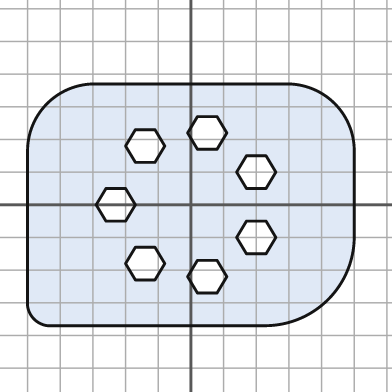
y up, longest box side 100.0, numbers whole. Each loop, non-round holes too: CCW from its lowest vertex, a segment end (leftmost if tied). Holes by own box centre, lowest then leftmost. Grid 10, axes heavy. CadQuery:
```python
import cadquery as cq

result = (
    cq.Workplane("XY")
    .moveTo(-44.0, -37.0)
    .lineTo(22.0, -37.0)
    .threePointArc((42.0, -29.0), (50.0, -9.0))
    .lineTo(50.0, 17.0)
    .threePointArc((44.0, 31.0), (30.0, 37.0))
    .lineTo(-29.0, 37.0)
    .threePointArc((-44.0, 31.0), (-50.0, 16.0))
    .lineTo(-50.0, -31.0)
    .threePointArc((-48.0, -35.0), (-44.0, -37.0))
    .close()
    .moveTo(2.0, -27.0)
    .lineTo(8.0, -27.0)
    .lineTo(11.0, -22.0)
    .lineTo(8.0, -17.0)
    .lineTo(2.0, -17.0)
    .lineTo(-1.0, -22.0)
    .close()
    .moveTo(-17.0, -23.0)
    .lineTo(-11.0, -23.0)
    .lineTo(-8.0, -18.0)
    .lineTo(-11.0, -13.0)
    .lineTo(-17.0, -13.0)
    .lineTo(-20.0, -18.0)
    .close()
    .moveTo(17.0, -15.0)
    .lineTo(23.0, -15.0)
    .lineTo(26.0, -10.0)
    .lineTo(23.0, -5.0)
    .lineTo(17.0, -5.0)
    .lineTo(14.0, -10.0)
    .close()
    .moveTo(-26.0, -5.0)
    .lineTo(-20.0, -5.0)
    .lineTo(-17.0, 0.0)
    .lineTo(-20.0, 5.0)
    .lineTo(-26.0, 5.0)
    .lineTo(-29.0, 0.0)
    .close()
    .moveTo(17.0, 5.0)
    .lineTo(23.0, 5.0)
    .lineTo(26.0, 10.0)
    .lineTo(23.0, 15.0)
    .lineTo(17.0, 15.0)
    .lineTo(14.0, 10.0)
    .close()
    .moveTo(-17.0, 13.0)
    .lineTo(-11.0, 13.0)
    .lineTo(-8.0, 18.0)
    .lineTo(-11.0, 23.0)
    .lineTo(-17.0, 23.0)
    .lineTo(-20.0, 18.0)
    .close()
    .moveTo(2.0, 17.0)
    .lineTo(8.0, 17.0)
    .lineTo(11.0, 22.0)
    .lineTo(8.0, 27.0)
    .lineTo(2.0, 27.0)
    .lineTo(-1.0, 22.0)
    .close()
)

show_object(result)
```